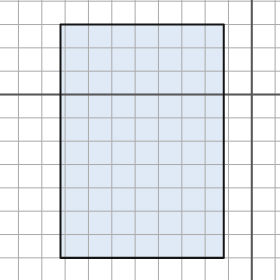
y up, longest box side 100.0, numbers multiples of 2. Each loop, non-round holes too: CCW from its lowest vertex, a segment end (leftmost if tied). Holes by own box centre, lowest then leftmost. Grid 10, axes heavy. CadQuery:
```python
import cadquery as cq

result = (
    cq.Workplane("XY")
    .moveTo(-82.0, -70.0)
    .lineTo(-12.0, -70.0)
    .lineTo(-12.0, 30.0)
    .lineTo(-82.0, 30.0)
    .close()
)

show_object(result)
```